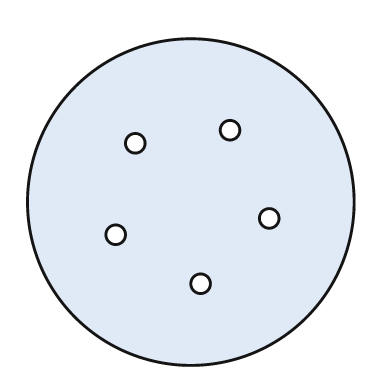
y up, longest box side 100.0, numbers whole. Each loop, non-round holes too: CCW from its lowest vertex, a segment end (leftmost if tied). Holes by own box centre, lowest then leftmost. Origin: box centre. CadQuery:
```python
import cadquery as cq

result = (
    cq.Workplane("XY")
    .moveTo(0.0, 0.0)
    .circle(50.0)
    .moveTo(3.0, -25.0)
    .circle(3.0)
    .moveTo(-23.0, -10.0)
    .circle(3.0)
    .moveTo(24.0, -5.0)
    .circle(3.0)
    .moveTo(-17.0, 18.0)
    .circle(3.0)
    .moveTo(12.0, 22.0)
    .circle(3.0)
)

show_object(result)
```